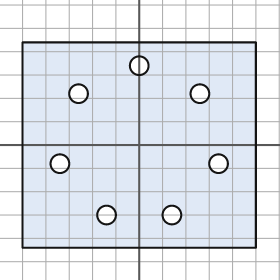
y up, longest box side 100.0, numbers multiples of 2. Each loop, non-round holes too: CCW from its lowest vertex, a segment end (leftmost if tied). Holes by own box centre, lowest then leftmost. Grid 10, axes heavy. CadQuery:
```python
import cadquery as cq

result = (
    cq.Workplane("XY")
    .moveTo(-50.0, -44.0)
    .lineTo(50.0, -44.0)
    .lineTo(50.0, 44.0)
    .lineTo(-50.0, 44.0)
    .close()
    .moveTo(-14.0, -30.0)
    .circle(4.0)
    .moveTo(14.0, -30.0)
    .circle(4.0)
    .moveTo(-34.0, -8.0)
    .circle(4.0)
    .moveTo(34.0, -8.0)
    .circle(4.0)
    .moveTo(-26.0, 22.0)
    .circle(4.0)
    .moveTo(26.0, 22.0)
    .circle(4.0)
    .moveTo(0.0, 34.0)
    .circle(4.0)
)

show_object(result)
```